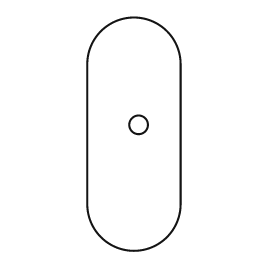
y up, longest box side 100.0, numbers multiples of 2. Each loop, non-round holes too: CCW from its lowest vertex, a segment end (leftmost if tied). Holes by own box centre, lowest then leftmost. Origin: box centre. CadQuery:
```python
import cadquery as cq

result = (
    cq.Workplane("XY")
    .moveTo(-20.0, -30.0)
    .threePointArc((0.0, -50.0), (20.0, -30.0))
    .lineTo(20.0, 30.0)
    .threePointArc((0.0, 50.0), (-20.0, 30.0))
    .close()
    .moveTo(2.0, 4.0)
    .circle(4.0)
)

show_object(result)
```